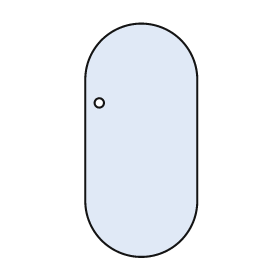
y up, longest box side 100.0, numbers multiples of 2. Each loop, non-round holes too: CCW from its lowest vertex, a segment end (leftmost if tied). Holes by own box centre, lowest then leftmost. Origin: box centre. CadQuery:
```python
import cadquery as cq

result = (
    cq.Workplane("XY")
    .moveTo(-24.0, -26.0)
    .threePointArc((0.0, -50.0), (24.0, -26.0))
    .lineTo(24.0, 26.0)
    .threePointArc((0.0, 50.0), (-24.0, 26.0))
    .close()
    .moveTo(-18.0, 16.0)
    .circle(2.0)
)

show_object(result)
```